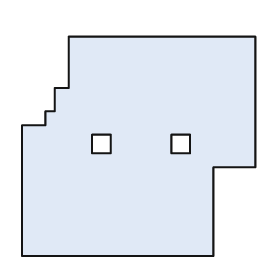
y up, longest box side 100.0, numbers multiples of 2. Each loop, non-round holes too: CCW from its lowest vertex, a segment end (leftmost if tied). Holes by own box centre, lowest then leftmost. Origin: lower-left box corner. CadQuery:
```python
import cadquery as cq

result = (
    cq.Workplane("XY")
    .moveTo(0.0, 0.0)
    .lineTo(82.0, 0.0)
    .lineTo(82.0, 38.0)
    .lineTo(100.0, 38.0)
    .lineTo(100.0, 94.0)
    .lineTo(20.0, 94.0)
    .lineTo(20.0, 72.0)
    .lineTo(14.0, 72.0)
    .lineTo(14.0, 62.0)
    .lineTo(10.0, 62.0)
    .lineTo(10.0, 56.0)
    .lineTo(0.0, 56.0)
    .close()
    .moveTo(30.0, 44.0)
    .lineTo(38.0, 44.0)
    .lineTo(38.0, 52.0)
    .lineTo(30.0, 52.0)
    .close()
    .moveTo(64.0, 44.0)
    .lineTo(72.0, 44.0)
    .lineTo(72.0, 52.0)
    .lineTo(64.0, 52.0)
    .close()
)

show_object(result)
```